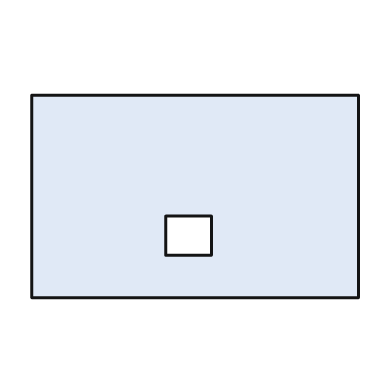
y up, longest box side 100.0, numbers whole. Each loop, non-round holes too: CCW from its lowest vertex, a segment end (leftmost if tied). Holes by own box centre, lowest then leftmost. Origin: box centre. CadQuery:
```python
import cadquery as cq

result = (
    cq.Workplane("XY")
    .moveTo(-50.0, -31.0)
    .lineTo(50.0, -31.0)
    .lineTo(50.0, 31.0)
    .lineTo(-50.0, 31.0)
    .close()
    .moveTo(-9.0, -18.0)
    .lineTo(5.0, -18.0)
    .lineTo(5.0, -6.0)
    .lineTo(-9.0, -6.0)
    .close()
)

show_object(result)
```